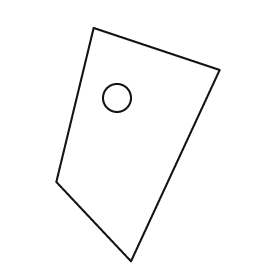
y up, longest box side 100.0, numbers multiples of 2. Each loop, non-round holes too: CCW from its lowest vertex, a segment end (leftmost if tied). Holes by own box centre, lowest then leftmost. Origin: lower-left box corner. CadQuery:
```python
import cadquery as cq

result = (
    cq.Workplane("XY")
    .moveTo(32.0, 0.0)
    .lineTo(70.0, 82.0)
    .lineTo(16.0, 100.0)
    .lineTo(0.0, 34.0)
    .close()
    .moveTo(26.0, 70.0)
    .circle(6.0)
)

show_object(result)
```